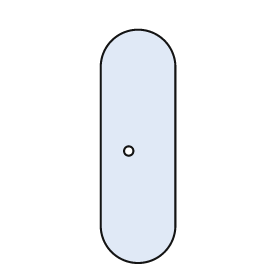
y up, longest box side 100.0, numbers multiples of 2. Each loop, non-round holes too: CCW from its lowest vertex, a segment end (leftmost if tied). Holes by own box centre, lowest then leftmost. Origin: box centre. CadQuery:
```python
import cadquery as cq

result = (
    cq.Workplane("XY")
    .moveTo(-16.0, -34.0)
    .threePointArc((0.0, -50.0), (16.0, -34.0))
    .lineTo(16.0, 34.0)
    .threePointArc((0.0, 50.0), (-16.0, 34.0))
    .close()
    .moveTo(-4.0, -2.0)
    .circle(2.0)
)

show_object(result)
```